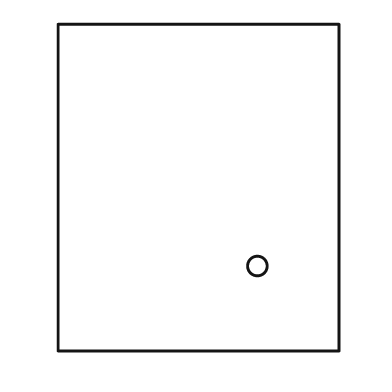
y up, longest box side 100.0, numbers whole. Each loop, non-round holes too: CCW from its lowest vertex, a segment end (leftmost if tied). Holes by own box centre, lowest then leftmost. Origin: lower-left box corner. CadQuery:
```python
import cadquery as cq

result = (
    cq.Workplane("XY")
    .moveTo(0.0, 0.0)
    .lineTo(86.0, 0.0)
    .lineTo(86.0, 100.0)
    .lineTo(0.0, 100.0)
    .close()
    .moveTo(61.0, 26.0)
    .circle(3.0)
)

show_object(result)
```